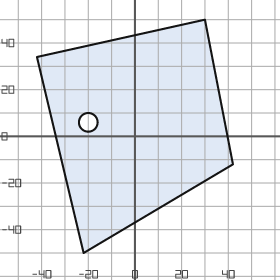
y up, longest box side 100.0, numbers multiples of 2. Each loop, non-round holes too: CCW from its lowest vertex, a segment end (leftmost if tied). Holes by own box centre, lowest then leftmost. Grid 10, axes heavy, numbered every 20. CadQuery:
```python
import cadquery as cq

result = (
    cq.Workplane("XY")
    .moveTo(-22.0, -50.0)
    .lineTo(42.0, -12.0)
    .lineTo(30.0, 50.0)
    .lineTo(-42.0, 34.0)
    .close()
    .moveTo(-20.0, 6.0)
    .circle(4.0)
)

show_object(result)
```